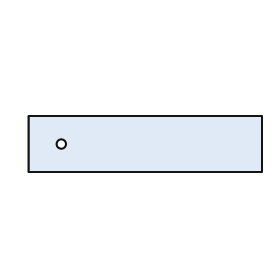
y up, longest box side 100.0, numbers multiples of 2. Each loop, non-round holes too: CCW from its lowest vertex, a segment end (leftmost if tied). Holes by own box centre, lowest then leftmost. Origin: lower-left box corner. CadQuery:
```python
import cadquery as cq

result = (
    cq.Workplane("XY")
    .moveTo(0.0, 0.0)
    .lineTo(100.0, 0.0)
    .lineTo(100.0, 24.0)
    .lineTo(0.0, 24.0)
    .close()
    .moveTo(14.0, 12.0)
    .circle(2.0)
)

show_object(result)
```